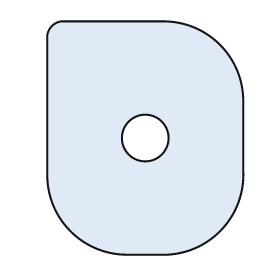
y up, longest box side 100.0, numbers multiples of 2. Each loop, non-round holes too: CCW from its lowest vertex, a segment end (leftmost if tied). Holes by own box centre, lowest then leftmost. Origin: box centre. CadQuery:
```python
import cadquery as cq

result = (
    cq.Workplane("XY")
    .moveTo(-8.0, -50.0)
    .lineTo(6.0, -50.0)
    .threePointArc((32.0, -40.0), (42.0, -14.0))
    .lineTo(42.0, 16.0)
    .threePointArc((32.0, 40.0), (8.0, 50.0))
    .lineTo(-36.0, 50.0)
    .threePointArc((-40.0, 48.0), (-42.0, 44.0))
    .lineTo(-42.0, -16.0)
    .threePointArc((-32.0, -40.0), (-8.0, -50.0))
    .close()
    .moveTo(0.0, 0.0)
    .circle(10.0)
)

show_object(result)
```